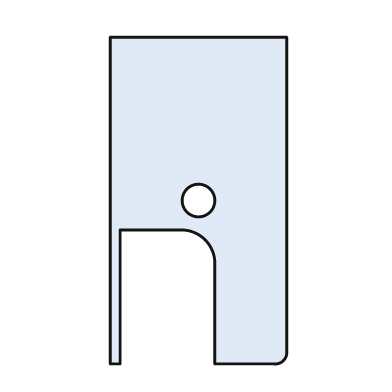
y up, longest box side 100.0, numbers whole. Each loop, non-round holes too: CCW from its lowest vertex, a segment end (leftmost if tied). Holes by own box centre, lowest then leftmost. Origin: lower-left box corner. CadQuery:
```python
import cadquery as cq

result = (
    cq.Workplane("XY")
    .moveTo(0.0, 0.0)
    .lineTo(3.0, 0.0)
    .lineTo(3.0, 41.0)
    .lineTo(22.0, 41.0)
    .threePointArc((29.0, 38.0), (32.0, 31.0))
    .lineTo(32.0, 0.0)
    .lineTo(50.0, 0.0)
    .threePointArc((53.0, 1.0), (54.0, 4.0))
    .lineTo(54.0, 100.0)
    .lineTo(0.0, 100.0)
    .close()
    .moveTo(27.0, 50.0)
    .circle(5.0)
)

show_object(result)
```